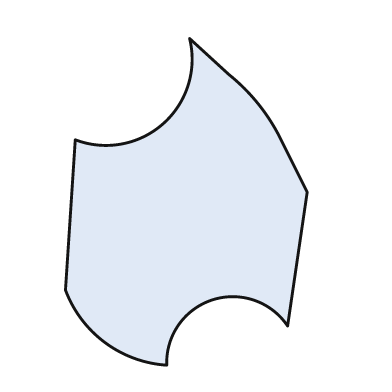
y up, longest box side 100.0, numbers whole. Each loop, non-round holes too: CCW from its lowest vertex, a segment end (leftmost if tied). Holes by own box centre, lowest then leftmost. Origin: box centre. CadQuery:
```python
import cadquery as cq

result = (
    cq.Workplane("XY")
    .moveTo(-6.0, -50.0)
    .threePointArc((8.0, -30.0), (31.0, -38.0))
    .lineTo(37.0, 3.0)
    .lineTo(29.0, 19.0)
    .threePointArc((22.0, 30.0), (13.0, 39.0))
    .lineTo(1.0, 50.0)
    .threePointArc((-7.0, 24.0), (-34.0, 19.0))
    .lineTo(-37.0, -27.0)
    .threePointArc((-25.0, -43.0), (-6.0, -50.0))
    .close()
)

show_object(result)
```